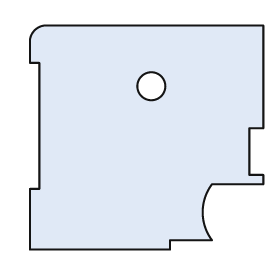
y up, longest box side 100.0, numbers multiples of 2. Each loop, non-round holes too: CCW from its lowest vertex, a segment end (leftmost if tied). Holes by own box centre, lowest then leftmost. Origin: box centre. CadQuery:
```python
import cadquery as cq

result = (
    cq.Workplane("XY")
    .moveTo(-50.0, -48.0)
    .lineTo(10.0, -48.0)
    .lineTo(10.0, -44.0)
    .lineTo(28.0, -44.0)
    .threePointArc((24.0, -32.0), (28.0, -20.0))
    .lineTo(50.0, -20.0)
    .lineTo(50.0, -16.0)
    .lineTo(44.0, -16.0)
    .lineTo(44.0, 4.0)
    .lineTo(50.0, 4.0)
    .lineTo(50.0, 48.0)
    .lineTo(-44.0, 48.0)
    .threePointArc((-48.0, 46.0), (-50.0, 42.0))
    .lineTo(-50.0, 32.0)
    .lineTo(-46.0, 32.0)
    .lineTo(-46.0, -22.0)
    .lineTo(-50.0, -22.0)
    .close()
    .moveTo(2.0, 22.0)
    .circle(6.0)
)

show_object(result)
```